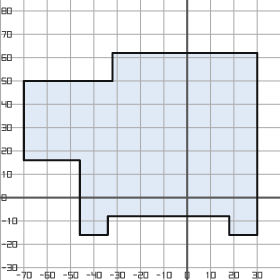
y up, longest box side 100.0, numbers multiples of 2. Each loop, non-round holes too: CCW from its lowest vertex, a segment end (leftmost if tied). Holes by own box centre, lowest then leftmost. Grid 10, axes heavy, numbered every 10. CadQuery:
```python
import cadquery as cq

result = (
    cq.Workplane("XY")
    .moveTo(-46.0, -16.0)
    .lineTo(-34.0, -16.0)
    .lineTo(-34.0, -8.0)
    .lineTo(18.0, -8.0)
    .lineTo(18.0, -16.0)
    .lineTo(30.0, -16.0)
    .lineTo(30.0, 62.0)
    .lineTo(-32.0, 62.0)
    .lineTo(-32.0, 50.0)
    .lineTo(-70.0, 50.0)
    .lineTo(-70.0, 16.0)
    .lineTo(-46.0, 16.0)
    .close()
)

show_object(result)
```